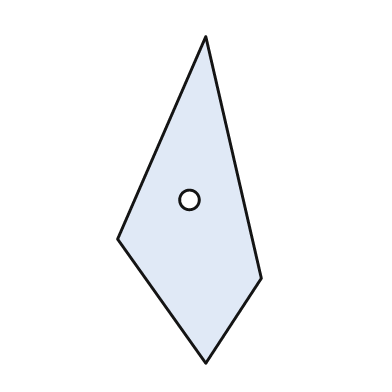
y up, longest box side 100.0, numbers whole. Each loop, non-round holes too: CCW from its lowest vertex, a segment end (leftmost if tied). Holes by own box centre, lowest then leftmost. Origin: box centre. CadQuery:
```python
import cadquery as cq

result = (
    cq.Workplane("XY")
    .moveTo(5.0, -50.0)
    .lineTo(22.0, -24.0)
    .lineTo(5.0, 50.0)
    .lineTo(-22.0, -12.0)
    .close()
    .moveTo(0.0, 0.0)
    .circle(3.0)
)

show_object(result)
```